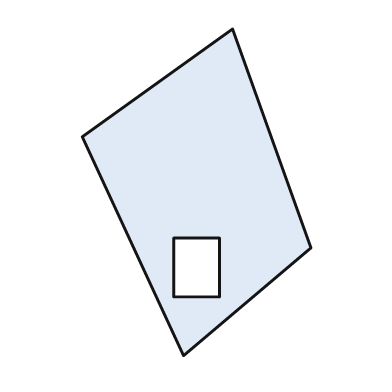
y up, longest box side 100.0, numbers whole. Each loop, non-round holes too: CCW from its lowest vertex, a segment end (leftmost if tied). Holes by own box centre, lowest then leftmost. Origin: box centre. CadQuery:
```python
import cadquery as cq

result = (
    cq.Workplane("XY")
    .moveTo(-4.0, -50.0)
    .lineTo(35.0, -17.0)
    .lineTo(11.0, 50.0)
    .lineTo(-35.0, 17.0)
    .close()
    .moveTo(-7.0, -32.0)
    .lineTo(7.0, -32.0)
    .lineTo(7.0, -14.0)
    .lineTo(-7.0, -14.0)
    .close()
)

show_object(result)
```